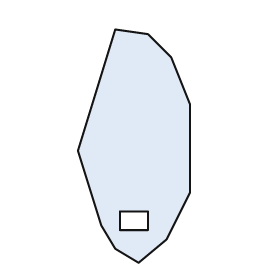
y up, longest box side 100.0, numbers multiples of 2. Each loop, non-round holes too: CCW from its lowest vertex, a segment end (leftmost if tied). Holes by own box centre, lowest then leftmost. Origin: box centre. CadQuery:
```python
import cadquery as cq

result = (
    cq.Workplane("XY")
    .moveTo(2.0, -50.0)
    .lineTo(14.0, -40.0)
    .lineTo(24.0, -20.0)
    .lineTo(24.0, 18.0)
    .lineTo(16.0, 38.0)
    .lineTo(6.0, 48.0)
    .lineTo(-8.0, 50.0)
    .lineTo(-24.0, -2.0)
    .lineTo(-14.0, -34.0)
    .lineTo(-8.0, -44.0)
    .close()
    .moveTo(-6.0, -36.0)
    .lineTo(6.0, -36.0)
    .lineTo(6.0, -28.0)
    .lineTo(-6.0, -28.0)
    .close()
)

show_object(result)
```